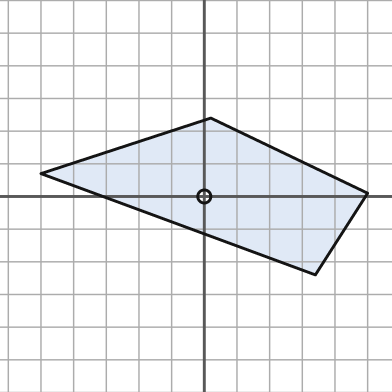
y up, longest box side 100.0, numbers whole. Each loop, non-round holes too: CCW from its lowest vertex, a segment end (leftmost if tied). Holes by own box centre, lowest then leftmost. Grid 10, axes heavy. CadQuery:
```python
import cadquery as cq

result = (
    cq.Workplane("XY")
    .moveTo(34.0, -24.0)
    .lineTo(50.0, 1.0)
    .lineTo(2.0, 24.0)
    .lineTo(-50.0, 7.0)
    .close()
    .moveTo(0.0, 0.0)
    .circle(2.0)
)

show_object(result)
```